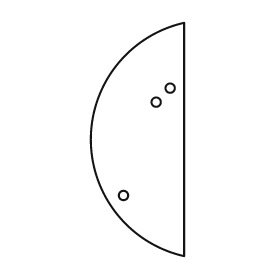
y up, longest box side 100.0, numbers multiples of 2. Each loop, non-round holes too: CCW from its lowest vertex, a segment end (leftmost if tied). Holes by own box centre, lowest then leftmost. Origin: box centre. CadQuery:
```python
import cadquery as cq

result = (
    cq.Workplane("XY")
    .moveTo(20.0, -50.0)
    .lineTo(20.0, 50.0)
    .threePointArc((-20.0, 0.0), (20.0, -50.0))
    .close()
    .moveTo(-6.0, -24.0)
    .circle(2.0)
    .moveTo(8.0, 16.0)
    .circle(2.0)
    .moveTo(14.0, 22.0)
    .circle(2.0)
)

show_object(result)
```